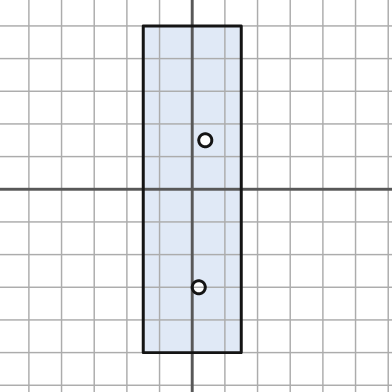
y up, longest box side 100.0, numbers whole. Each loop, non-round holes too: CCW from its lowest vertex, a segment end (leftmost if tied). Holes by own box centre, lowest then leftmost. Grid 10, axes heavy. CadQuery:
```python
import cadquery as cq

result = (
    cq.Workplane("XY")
    .moveTo(-15.0, -50.0)
    .lineTo(15.0, -50.0)
    .lineTo(15.0, 50.0)
    .lineTo(-15.0, 50.0)
    .close()
    .moveTo(2.0, -30.0)
    .circle(2.0)
    .moveTo(4.0, 15.0)
    .circle(2.0)
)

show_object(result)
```